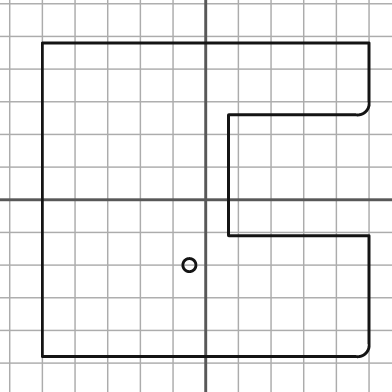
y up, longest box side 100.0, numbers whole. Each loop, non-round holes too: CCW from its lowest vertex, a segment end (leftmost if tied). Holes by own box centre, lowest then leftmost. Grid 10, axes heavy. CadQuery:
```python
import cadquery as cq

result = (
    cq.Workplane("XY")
    .moveTo(-50.0, -48.0)
    .lineTo(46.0, -48.0)
    .threePointArc((49.0, -47.0), (50.0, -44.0))
    .lineTo(50.0, -11.0)
    .lineTo(7.0, -11.0)
    .lineTo(7.0, 26.0)
    .lineTo(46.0, 26.0)
    .threePointArc((49.0, 27.0), (50.0, 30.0))
    .lineTo(50.0, 48.0)
    .lineTo(-50.0, 48.0)
    .close()
    .moveTo(-5.0, -20.0)
    .circle(2.0)
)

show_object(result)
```